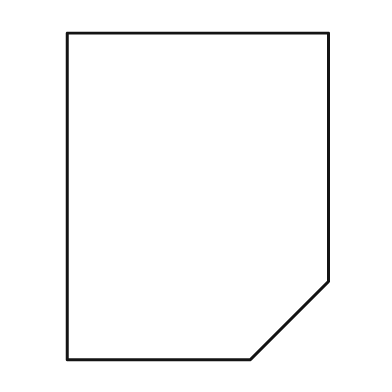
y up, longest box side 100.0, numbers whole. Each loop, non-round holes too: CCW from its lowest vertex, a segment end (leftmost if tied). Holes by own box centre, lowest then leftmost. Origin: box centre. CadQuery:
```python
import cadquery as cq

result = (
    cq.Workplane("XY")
    .moveTo(-40.0, -50.0)
    .lineTo(16.0, -50.0)
    .lineTo(40.0, -26.0)
    .lineTo(40.0, 50.0)
    .lineTo(-40.0, 50.0)
    .close()
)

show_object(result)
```